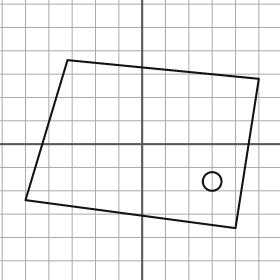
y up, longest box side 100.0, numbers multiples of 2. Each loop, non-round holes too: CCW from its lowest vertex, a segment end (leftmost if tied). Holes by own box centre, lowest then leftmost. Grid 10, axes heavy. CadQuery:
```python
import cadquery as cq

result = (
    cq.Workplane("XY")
    .moveTo(40.0, -36.0)
    .lineTo(50.0, 28.0)
    .lineTo(-32.0, 36.0)
    .lineTo(-50.0, -24.0)
    .close()
    .moveTo(30.0, -16.0)
    .circle(4.0)
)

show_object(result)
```